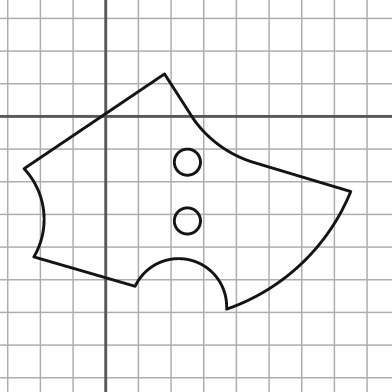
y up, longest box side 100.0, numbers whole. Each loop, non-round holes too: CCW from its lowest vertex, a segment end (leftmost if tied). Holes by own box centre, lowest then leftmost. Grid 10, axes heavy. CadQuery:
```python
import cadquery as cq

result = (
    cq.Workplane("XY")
    .moveTo(37.0, -59.0)
    .threePointArc((60.0, -45.0), (75.0, -23.0))
    .lineTo(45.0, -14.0)
    .threePointArc((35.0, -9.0), (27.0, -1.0))
    .lineTo(18.0, 13.0)
    .lineTo(-25.0, -16.0)
    .threePointArc((-19.0, -29.0), (-22.0, -43.0))
    .lineTo(9.0, -52.0)
    .threePointArc((26.0, -44.0), (37.0, -59.0))
    .close()
    .moveTo(25.0, -32.0)
    .circle(4.0)
    .moveTo(25.0, -14.0)
    .circle(4.0)
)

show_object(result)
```